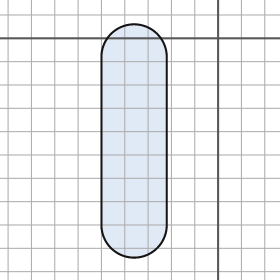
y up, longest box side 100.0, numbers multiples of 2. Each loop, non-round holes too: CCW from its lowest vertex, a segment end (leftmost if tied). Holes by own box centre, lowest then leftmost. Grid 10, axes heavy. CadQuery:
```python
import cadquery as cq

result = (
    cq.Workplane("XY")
    .moveTo(-50.0, -80.0)
    .threePointArc((-36.0, -94.0), (-22.0, -80.0))
    .lineTo(-22.0, -8.0)
    .threePointArc((-36.0, 6.0), (-50.0, -8.0))
    .close()
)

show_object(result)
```